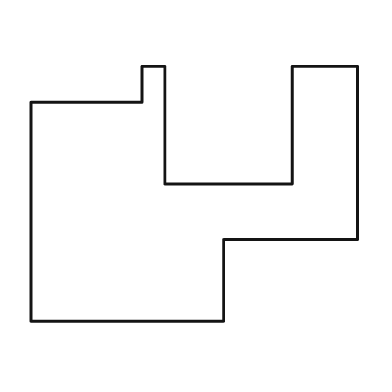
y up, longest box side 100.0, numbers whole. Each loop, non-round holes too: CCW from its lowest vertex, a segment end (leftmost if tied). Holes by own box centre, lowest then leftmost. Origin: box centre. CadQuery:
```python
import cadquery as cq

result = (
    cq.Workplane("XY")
    .moveTo(-50.0, -39.0)
    .lineTo(9.0, -39.0)
    .lineTo(9.0, -14.0)
    .lineTo(50.0, -14.0)
    .lineTo(50.0, 39.0)
    .lineTo(30.0, 39.0)
    .lineTo(30.0, 3.0)
    .lineTo(-9.0, 3.0)
    .lineTo(-9.0, 39.0)
    .lineTo(-16.0, 39.0)
    .lineTo(-16.0, 28.0)
    .lineTo(-50.0, 28.0)
    .close()
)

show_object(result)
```